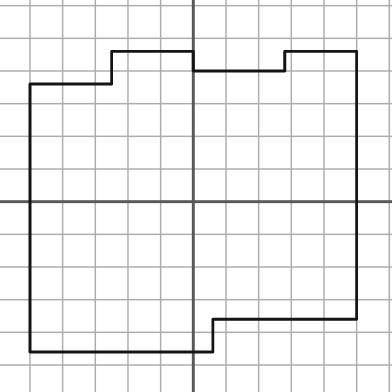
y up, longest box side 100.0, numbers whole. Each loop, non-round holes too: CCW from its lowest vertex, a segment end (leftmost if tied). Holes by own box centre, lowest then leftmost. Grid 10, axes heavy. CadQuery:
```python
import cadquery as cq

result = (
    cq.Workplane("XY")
    .moveTo(-50.0, -46.0)
    .lineTo(6.0, -46.0)
    .lineTo(6.0, -36.0)
    .lineTo(50.0, -36.0)
    .lineTo(50.0, 46.0)
    .lineTo(28.0, 46.0)
    .lineTo(28.0, 40.0)
    .lineTo(0.0, 40.0)
    .lineTo(0.0, 46.0)
    .lineTo(-25.0, 46.0)
    .lineTo(-25.0, 36.0)
    .lineTo(-50.0, 36.0)
    .close()
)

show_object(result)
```